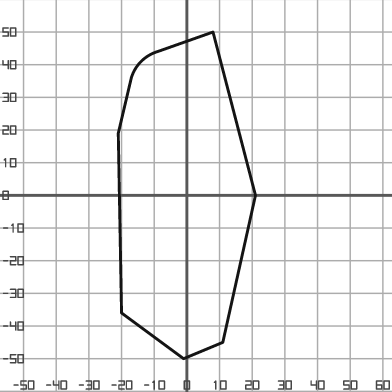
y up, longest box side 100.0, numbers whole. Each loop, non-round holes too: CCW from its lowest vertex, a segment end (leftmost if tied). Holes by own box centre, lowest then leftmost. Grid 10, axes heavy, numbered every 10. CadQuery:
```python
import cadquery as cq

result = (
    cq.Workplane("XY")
    .moveTo(-1.0, -50.0)
    .lineTo(11.0, -45.0)
    .lineTo(21.0, 0.0)
    .lineTo(8.0, 50.0)
    .lineTo(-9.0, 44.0)
    .threePointArc((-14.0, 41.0), (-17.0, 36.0))
    .lineTo(-21.0, 19.0)
    .lineTo(-20.0, -36.0)
    .close()
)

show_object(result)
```